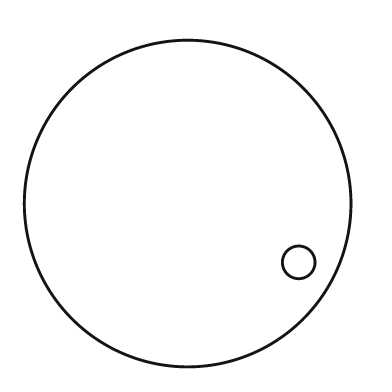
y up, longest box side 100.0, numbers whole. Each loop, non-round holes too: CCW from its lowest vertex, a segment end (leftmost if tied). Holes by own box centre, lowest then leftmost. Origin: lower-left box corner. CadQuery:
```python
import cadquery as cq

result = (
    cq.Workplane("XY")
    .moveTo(50.0, 50.0)
    .circle(50.0)
    .moveTo(84.0, 32.0)
    .circle(5.0)
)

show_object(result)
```